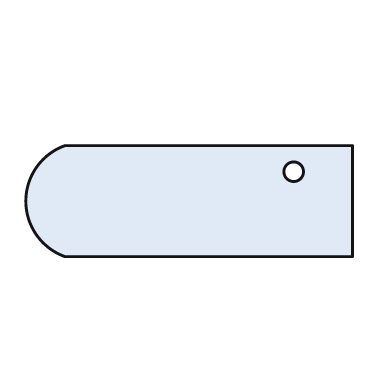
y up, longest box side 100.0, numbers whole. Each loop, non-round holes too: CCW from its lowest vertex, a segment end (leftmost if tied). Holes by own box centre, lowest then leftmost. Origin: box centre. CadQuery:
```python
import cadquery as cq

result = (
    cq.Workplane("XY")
    .moveTo(-38.0, -17.0)
    .lineTo(50.0, -17.0)
    .lineTo(50.0, 17.0)
    .lineTo(-38.0, 17.0)
    .threePointArc((-50.0, 0.0), (-38.0, -17.0))
    .close()
    .moveTo(32.0, 9.0)
    .circle(3.0)
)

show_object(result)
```